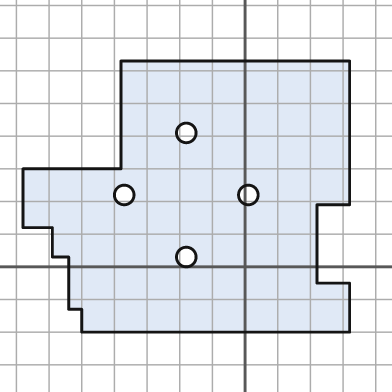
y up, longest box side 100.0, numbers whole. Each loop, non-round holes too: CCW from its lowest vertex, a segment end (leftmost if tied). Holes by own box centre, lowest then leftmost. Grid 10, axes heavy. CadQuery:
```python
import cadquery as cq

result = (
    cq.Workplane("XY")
    .moveTo(-50.0, -20.0)
    .lineTo(32.0, -20.0)
    .lineTo(32.0, -5.0)
    .lineTo(22.0, -5.0)
    .lineTo(22.0, 19.0)
    .lineTo(32.0, 19.0)
    .lineTo(32.0, 63.0)
    .lineTo(-38.0, 63.0)
    .lineTo(-38.0, 30.0)
    .lineTo(-68.0, 30.0)
    .lineTo(-68.0, 12.0)
    .lineTo(-59.0, 12.0)
    .lineTo(-59.0, 3.0)
    .lineTo(-54.0, 3.0)
    .lineTo(-54.0, -13.0)
    .lineTo(-50.0, -13.0)
    .close()
    .moveTo(-18.0, 3.0)
    .circle(3.0)
    .moveTo(-37.0, 22.0)
    .circle(3.0)
    .moveTo(1.0, 22.0)
    .circle(3.0)
    .moveTo(-18.0, 41.0)
    .circle(3.0)
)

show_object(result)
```